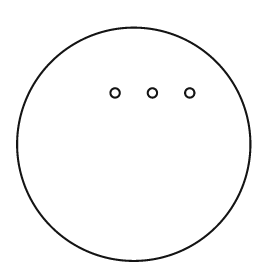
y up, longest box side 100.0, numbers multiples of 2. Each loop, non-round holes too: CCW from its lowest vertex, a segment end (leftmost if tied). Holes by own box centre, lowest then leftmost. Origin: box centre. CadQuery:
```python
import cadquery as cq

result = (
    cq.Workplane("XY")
    .moveTo(0.0, 0.0)
    .circle(50.0)
    .moveTo(-8.0, 22.0)
    .circle(2.0)
    .moveTo(8.0, 22.0)
    .circle(2.0)
    .moveTo(24.0, 22.0)
    .circle(2.0)
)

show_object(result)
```